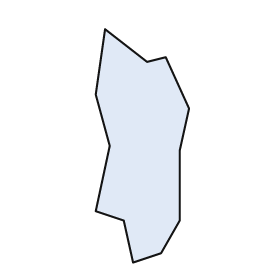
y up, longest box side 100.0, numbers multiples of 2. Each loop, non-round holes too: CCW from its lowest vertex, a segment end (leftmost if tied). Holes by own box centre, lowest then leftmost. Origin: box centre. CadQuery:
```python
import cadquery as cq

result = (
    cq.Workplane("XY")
    .moveTo(-4.0, -50.0)
    .lineTo(8.0, -46.0)
    .lineTo(16.0, -32.0)
    .lineTo(16.0, -2.0)
    .lineTo(20.0, 16.0)
    .lineTo(10.0, 38.0)
    .lineTo(2.0, 36.0)
    .lineTo(-16.0, 50.0)
    .lineTo(-20.0, 22.0)
    .lineTo(-14.0, 0.0)
    .lineTo(-20.0, -28.0)
    .lineTo(-8.0, -32.0)
    .close()
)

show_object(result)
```